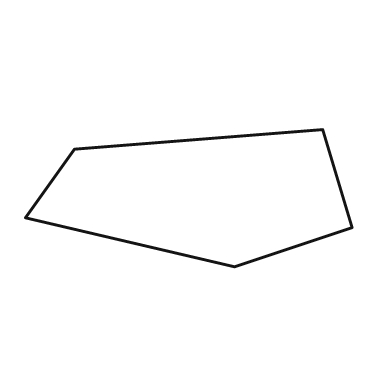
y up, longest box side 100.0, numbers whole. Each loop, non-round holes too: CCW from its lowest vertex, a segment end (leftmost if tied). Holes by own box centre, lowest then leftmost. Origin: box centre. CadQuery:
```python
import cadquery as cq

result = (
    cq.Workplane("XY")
    .moveTo(14.0, -21.0)
    .lineTo(50.0, -9.0)
    .lineTo(41.0, 21.0)
    .lineTo(-35.0, 15.0)
    .lineTo(-50.0, -6.0)
    .close()
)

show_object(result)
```